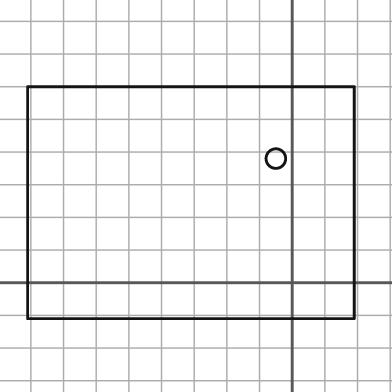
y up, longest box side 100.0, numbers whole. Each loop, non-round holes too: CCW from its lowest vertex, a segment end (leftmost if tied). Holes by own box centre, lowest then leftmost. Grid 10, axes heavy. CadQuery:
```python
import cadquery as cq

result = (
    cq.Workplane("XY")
    .moveTo(-81.0, -11.0)
    .lineTo(19.0, -11.0)
    .lineTo(19.0, 60.0)
    .lineTo(-81.0, 60.0)
    .close()
    .moveTo(-5.0, 38.0)
    .circle(3.0)
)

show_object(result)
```